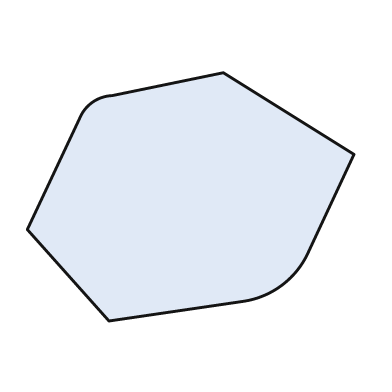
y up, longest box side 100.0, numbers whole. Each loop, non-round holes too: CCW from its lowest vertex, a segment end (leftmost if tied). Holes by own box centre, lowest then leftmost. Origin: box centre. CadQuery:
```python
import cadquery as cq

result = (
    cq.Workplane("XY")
    .moveTo(-25.0, -38.0)
    .lineTo(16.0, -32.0)
    .threePointArc((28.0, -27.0), (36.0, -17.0))
    .lineTo(50.0, 13.0)
    .lineTo(10.0, 38.0)
    .lineTo(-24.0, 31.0)
    .threePointArc((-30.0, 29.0), (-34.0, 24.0))
    .lineTo(-50.0, -10.0)
    .close()
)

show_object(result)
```